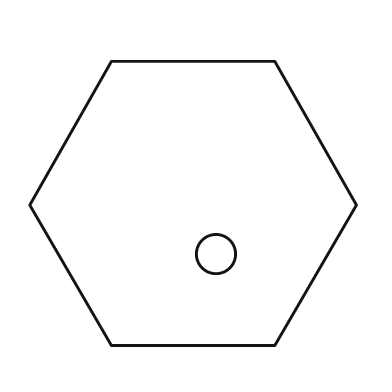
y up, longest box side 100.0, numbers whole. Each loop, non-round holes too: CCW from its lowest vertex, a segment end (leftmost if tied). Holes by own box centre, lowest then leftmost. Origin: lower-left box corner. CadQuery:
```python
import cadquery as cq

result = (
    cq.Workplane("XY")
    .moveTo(25.0, 0.0)
    .lineTo(75.0, 0.0)
    .lineTo(100.0, 43.0)
    .lineTo(75.0, 87.0)
    .lineTo(25.0, 87.0)
    .lineTo(0.0, 43.0)
    .close()
    .moveTo(57.0, 28.0)
    .circle(6.0)
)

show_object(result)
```